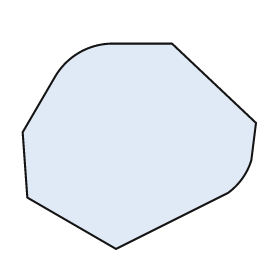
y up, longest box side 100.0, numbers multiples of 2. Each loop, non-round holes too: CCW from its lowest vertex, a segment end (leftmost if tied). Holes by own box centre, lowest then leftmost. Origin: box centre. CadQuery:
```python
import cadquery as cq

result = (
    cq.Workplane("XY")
    .moveTo(-10.0, -44.0)
    .lineTo(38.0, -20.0)
    .threePointArc((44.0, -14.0), (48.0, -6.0))
    .lineTo(50.0, 10.0)
    .lineTo(14.0, 44.0)
    .lineTo(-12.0, 44.0)
    .threePointArc((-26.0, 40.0), (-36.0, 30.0))
    .lineTo(-50.0, 6.0)
    .lineTo(-48.0, -22.0)
    .close()
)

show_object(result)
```